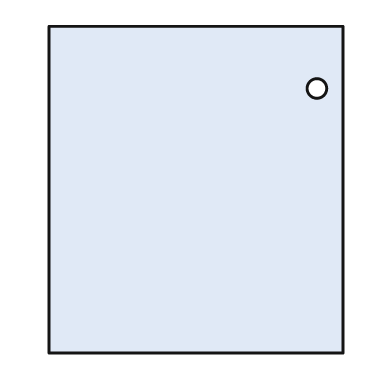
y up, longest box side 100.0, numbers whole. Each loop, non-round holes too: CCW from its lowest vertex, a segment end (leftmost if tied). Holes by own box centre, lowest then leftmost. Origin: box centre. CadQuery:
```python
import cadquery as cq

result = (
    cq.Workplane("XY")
    .moveTo(-45.0, -50.0)
    .lineTo(45.0, -50.0)
    .lineTo(45.0, 50.0)
    .lineTo(-45.0, 50.0)
    .close()
    .moveTo(37.0, 31.0)
    .circle(3.0)
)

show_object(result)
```